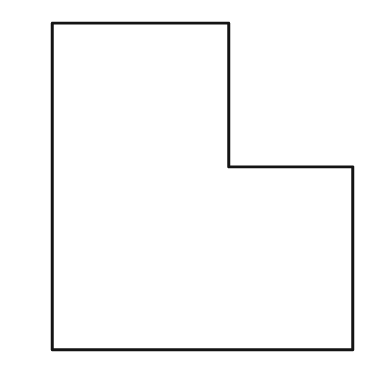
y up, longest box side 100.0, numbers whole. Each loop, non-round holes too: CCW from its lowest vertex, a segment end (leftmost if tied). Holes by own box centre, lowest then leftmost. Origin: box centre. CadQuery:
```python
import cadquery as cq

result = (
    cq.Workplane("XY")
    .moveTo(-46.0, -50.0)
    .lineTo(46.0, -50.0)
    .lineTo(46.0, 6.0)
    .lineTo(8.0, 6.0)
    .lineTo(8.0, 50.0)
    .lineTo(-46.0, 50.0)
    .close()
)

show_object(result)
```